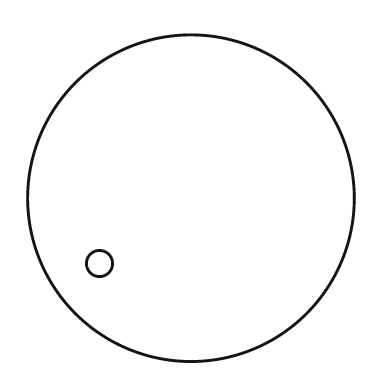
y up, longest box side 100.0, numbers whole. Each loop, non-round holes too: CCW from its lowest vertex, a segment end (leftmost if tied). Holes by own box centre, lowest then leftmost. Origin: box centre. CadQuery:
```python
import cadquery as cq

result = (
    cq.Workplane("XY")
    .moveTo(0.0, 0.0)
    .circle(50.0)
    .moveTo(-28.0, -20.0)
    .circle(4.0)
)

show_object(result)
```